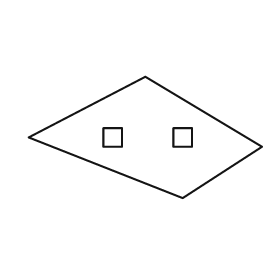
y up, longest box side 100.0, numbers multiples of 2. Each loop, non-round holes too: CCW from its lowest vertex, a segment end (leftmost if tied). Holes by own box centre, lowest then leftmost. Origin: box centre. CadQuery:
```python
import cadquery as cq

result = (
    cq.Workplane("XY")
    .moveTo(16.0, -26.0)
    .lineTo(50.0, -4.0)
    .lineTo(0.0, 26.0)
    .lineTo(-50.0, 0.0)
    .close()
    .moveTo(-18.0, -4.0)
    .lineTo(-10.0, -4.0)
    .lineTo(-10.0, 4.0)
    .lineTo(-18.0, 4.0)
    .close()
    .moveTo(12.0, -4.0)
    .lineTo(20.0, -4.0)
    .lineTo(20.0, 4.0)
    .lineTo(12.0, 4.0)
    .close()
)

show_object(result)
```